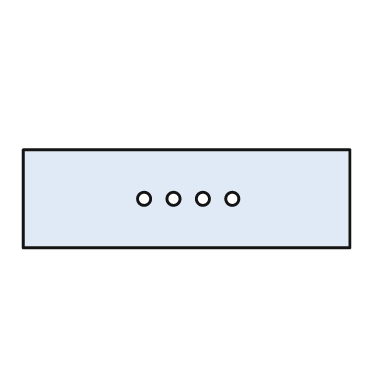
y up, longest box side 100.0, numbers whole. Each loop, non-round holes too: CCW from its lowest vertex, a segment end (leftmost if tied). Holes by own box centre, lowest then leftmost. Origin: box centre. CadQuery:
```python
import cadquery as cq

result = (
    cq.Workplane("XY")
    .moveTo(-50.0, -15.0)
    .lineTo(50.0, -15.0)
    .lineTo(50.0, 15.0)
    .lineTo(-50.0, 15.0)
    .close()
    .moveTo(-13.0, 0.0)
    .circle(2.0)
    .moveTo(-4.0, 0.0)
    .circle(2.0)
    .moveTo(5.0, 0.0)
    .circle(2.0)
    .moveTo(14.0, 0.0)
    .circle(2.0)
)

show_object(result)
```